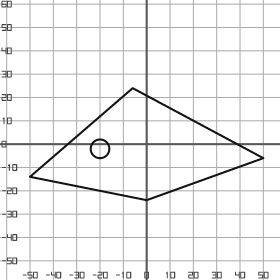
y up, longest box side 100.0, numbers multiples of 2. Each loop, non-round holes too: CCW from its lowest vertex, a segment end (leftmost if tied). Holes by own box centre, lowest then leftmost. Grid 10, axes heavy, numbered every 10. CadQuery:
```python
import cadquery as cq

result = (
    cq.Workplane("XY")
    .moveTo(0.0, -24.0)
    .lineTo(50.0, -6.0)
    .lineTo(-6.0, 24.0)
    .lineTo(-50.0, -14.0)
    .close()
    .moveTo(-20.0, -2.0)
    .circle(4.0)
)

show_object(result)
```